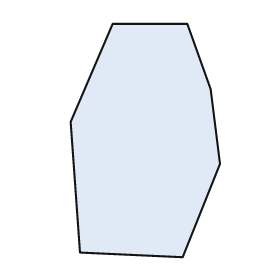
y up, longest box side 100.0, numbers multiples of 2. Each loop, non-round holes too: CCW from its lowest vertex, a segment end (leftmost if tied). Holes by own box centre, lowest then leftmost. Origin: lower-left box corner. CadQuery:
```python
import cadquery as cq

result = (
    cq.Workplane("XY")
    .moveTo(48.0, 0.0)
    .lineTo(64.0, 40.0)
    .lineTo(60.0, 72.0)
    .lineTo(50.0, 100.0)
    .lineTo(18.0, 100.0)
    .lineTo(0.0, 58.0)
    .lineTo(4.0, 2.0)
    .close()
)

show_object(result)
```